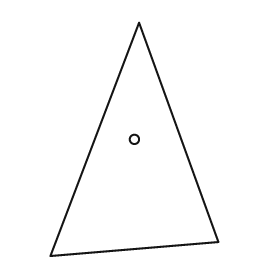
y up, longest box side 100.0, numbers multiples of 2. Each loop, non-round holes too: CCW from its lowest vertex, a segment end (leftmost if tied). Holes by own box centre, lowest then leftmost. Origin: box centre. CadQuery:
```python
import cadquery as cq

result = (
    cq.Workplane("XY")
    .moveTo(-36.0, -50.0)
    .lineTo(36.0, -44.0)
    .lineTo(2.0, 50.0)
    .close()
    .moveTo(0.0, 0.0)
    .circle(2.0)
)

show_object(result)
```